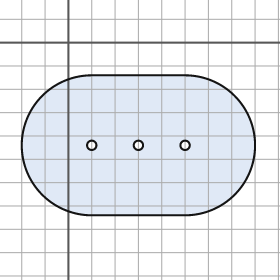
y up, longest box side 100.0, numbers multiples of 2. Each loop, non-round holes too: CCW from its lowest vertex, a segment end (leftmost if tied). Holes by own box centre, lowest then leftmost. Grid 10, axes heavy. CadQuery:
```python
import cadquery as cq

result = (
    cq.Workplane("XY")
    .moveTo(10.0, -74.0)
    .lineTo(50.0, -74.0)
    .threePointArc((80.0, -44.0), (50.0, -14.0))
    .lineTo(10.0, -14.0)
    .threePointArc((-20.0, -44.0), (10.0, -74.0))
    .close()
    .moveTo(10.0, -44.0)
    .circle(2.0)
    .moveTo(30.0, -44.0)
    .circle(2.0)
    .moveTo(50.0, -44.0)
    .circle(2.0)
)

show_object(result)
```